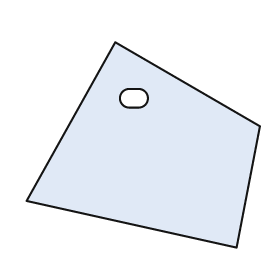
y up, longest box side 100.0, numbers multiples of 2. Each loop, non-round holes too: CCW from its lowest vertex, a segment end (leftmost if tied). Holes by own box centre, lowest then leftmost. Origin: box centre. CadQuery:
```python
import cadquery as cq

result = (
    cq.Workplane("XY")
    .moveTo(40.0, -44.0)
    .lineTo(50.0, 8.0)
    .lineTo(-12.0, 44.0)
    .lineTo(-50.0, -24.0)
    .close()
    .moveTo(-6.0, 16.0)
    .lineTo(-2.0, 16.0)
    .threePointArc((2.0, 20.0), (-2.0, 24.0))
    .lineTo(-6.0, 24.0)
    .threePointArc((-10.0, 20.0), (-6.0, 16.0))
    .close()
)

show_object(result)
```